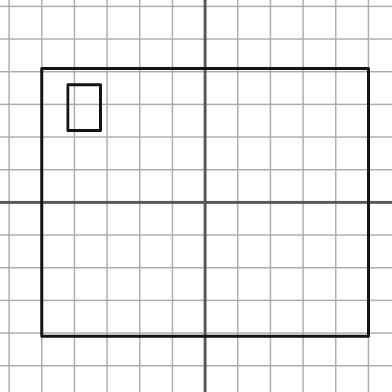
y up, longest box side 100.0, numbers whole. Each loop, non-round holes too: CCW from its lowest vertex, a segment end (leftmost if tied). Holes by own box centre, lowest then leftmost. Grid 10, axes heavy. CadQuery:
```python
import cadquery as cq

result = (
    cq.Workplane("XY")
    .moveTo(-50.0, -41.0)
    .lineTo(50.0, -41.0)
    .lineTo(50.0, 41.0)
    .lineTo(-50.0, 41.0)
    .close()
    .moveTo(-42.0, 22.0)
    .lineTo(-32.0, 22.0)
    .lineTo(-32.0, 36.0)
    .lineTo(-42.0, 36.0)
    .close()
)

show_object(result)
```